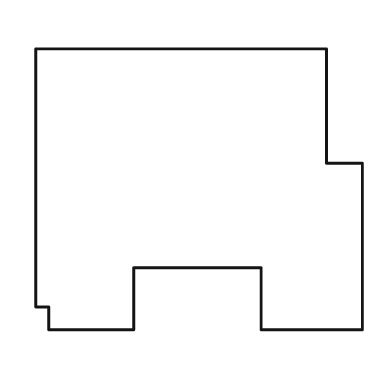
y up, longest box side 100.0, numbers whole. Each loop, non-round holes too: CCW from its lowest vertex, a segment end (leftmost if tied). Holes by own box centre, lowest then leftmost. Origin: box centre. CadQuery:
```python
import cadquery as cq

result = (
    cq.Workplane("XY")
    .moveTo(-46.0, -43.0)
    .lineTo(-20.0, -43.0)
    .lineTo(-20.0, -24.0)
    .lineTo(19.0, -24.0)
    .lineTo(19.0, -43.0)
    .lineTo(50.0, -43.0)
    .lineTo(50.0, 8.0)
    .lineTo(39.0, 8.0)
    .lineTo(39.0, 43.0)
    .lineTo(-50.0, 43.0)
    .lineTo(-50.0, -36.0)
    .lineTo(-46.0, -36.0)
    .close()
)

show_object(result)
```